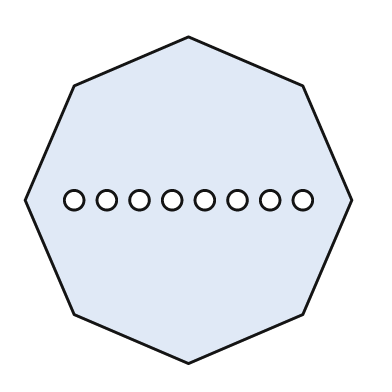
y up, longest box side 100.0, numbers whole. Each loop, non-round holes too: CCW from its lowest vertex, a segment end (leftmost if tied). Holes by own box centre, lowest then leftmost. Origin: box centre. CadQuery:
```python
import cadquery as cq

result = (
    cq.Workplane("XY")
    .moveTo(0.0, -50.0)
    .lineTo(35.0, -35.0)
    .lineTo(50.0, 0.0)
    .lineTo(35.0, 35.0)
    .lineTo(0.0, 50.0)
    .lineTo(-35.0, 35.0)
    .lineTo(-50.0, 0.0)
    .lineTo(-35.0, -35.0)
    .close()
    .moveTo(-35.0, 0.0)
    .circle(3.0)
    .moveTo(-25.0, 0.0)
    .circle(3.0)
    .moveTo(-15.0, 0.0)
    .circle(3.0)
    .moveTo(-5.0, 0.0)
    .circle(3.0)
    .moveTo(5.0, 0.0)
    .circle(3.0)
    .moveTo(15.0, 0.0)
    .circle(3.0)
    .moveTo(25.0, 0.0)
    .circle(3.0)
    .moveTo(35.0, 0.0)
    .circle(3.0)
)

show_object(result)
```